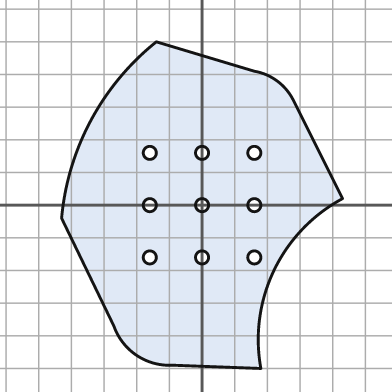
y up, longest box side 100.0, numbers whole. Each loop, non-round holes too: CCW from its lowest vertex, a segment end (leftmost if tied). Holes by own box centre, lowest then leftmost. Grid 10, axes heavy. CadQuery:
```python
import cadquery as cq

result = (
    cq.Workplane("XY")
    .moveTo(18.0, -50.0)
    .threePointArc((22.0, -20.0), (43.0, 2.0))
    .lineTo(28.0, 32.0)
    .threePointArc((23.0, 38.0), (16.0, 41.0))
    .lineTo(-14.0, 50.0)
    .threePointArc((-34.0, 26.0), (-43.0, -4.0))
    .lineTo(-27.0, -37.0)
    .threePointArc((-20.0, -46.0), (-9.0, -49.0))
    .close()
    .moveTo(-16.0, -16.0)
    .circle(2.0)
    .moveTo(0.0, -16.0)
    .circle(2.0)
    .moveTo(16.0, -16.0)
    .circle(2.0)
    .moveTo(-16.0, 0.0)
    .circle(2.0)
    .moveTo(0.0, 0.0)
    .circle(2.0)
    .moveTo(16.0, 0.0)
    .circle(2.0)
    .moveTo(-16.0, 16.0)
    .circle(2.0)
    .moveTo(0.0, 16.0)
    .circle(2.0)
    .moveTo(16.0, 16.0)
    .circle(2.0)
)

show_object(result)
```